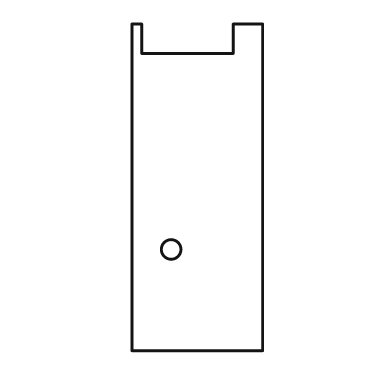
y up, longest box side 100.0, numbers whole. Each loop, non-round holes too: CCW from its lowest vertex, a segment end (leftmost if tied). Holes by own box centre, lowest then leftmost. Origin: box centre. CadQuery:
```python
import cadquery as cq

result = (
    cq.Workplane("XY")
    .moveTo(-20.0, -50.0)
    .lineTo(20.0, -50.0)
    .lineTo(20.0, 50.0)
    .lineTo(11.0, 50.0)
    .lineTo(11.0, 41.0)
    .lineTo(-17.0, 41.0)
    .lineTo(-17.0, 50.0)
    .lineTo(-20.0, 50.0)
    .close()
    .moveTo(-8.0, -19.0)
    .circle(3.0)
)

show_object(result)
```